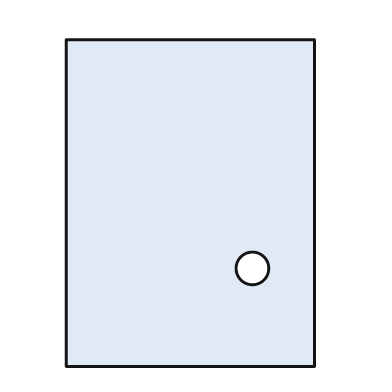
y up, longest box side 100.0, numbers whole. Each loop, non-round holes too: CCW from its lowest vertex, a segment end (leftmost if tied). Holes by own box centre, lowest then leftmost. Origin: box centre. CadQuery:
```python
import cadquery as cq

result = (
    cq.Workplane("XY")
    .moveTo(-38.0, -50.0)
    .lineTo(38.0, -50.0)
    .lineTo(38.0, 50.0)
    .lineTo(-38.0, 50.0)
    .close()
    .moveTo(19.0, -20.0)
    .circle(5.0)
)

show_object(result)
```